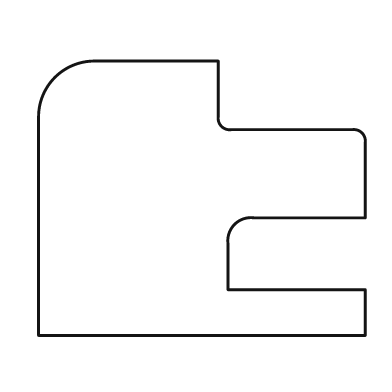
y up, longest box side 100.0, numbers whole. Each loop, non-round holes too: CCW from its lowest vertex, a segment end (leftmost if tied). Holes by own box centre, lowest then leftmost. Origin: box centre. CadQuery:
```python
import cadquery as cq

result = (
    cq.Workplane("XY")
    .moveTo(-50.0, -42.0)
    .lineTo(50.0, -42.0)
    .lineTo(50.0, -28.0)
    .lineTo(8.0, -28.0)
    .lineTo(8.0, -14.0)
    .threePointArc((10.0, -8.0), (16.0, -6.0))
    .lineTo(50.0, -6.0)
    .lineTo(50.0, 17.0)
    .threePointArc((49.0, 20.0), (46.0, 21.0))
    .lineTo(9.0, 21.0)
    .threePointArc((6.0, 22.0), (5.0, 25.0))
    .lineTo(5.0, 42.0)
    .lineTo(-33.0, 42.0)
    .threePointArc((-45.0, 37.0), (-50.0, 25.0))
    .close()
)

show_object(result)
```